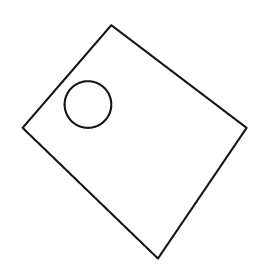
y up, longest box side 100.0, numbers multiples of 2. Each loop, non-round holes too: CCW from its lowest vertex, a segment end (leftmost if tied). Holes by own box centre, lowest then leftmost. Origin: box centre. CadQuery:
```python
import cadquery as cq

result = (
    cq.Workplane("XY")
    .moveTo(10.0, -50.0)
    .lineTo(48.0, 6.0)
    .lineTo(-10.0, 50.0)
    .lineTo(-48.0, 6.0)
    .close()
    .moveTo(-20.0, 16.0)
    .circle(10.0)
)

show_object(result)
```